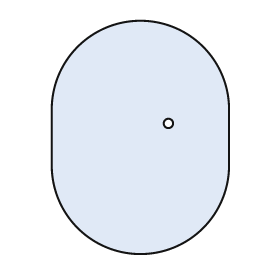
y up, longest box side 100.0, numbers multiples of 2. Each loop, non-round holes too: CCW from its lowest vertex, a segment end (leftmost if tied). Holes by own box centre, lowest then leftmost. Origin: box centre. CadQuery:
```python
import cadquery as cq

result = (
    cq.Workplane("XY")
    .moveTo(-38.0, -12.0)
    .threePointArc((0.0, -50.0), (38.0, -12.0))
    .lineTo(38.0, 12.0)
    .threePointArc((0.0, 50.0), (-38.0, 12.0))
    .close()
    .moveTo(12.0, 6.0)
    .circle(2.0)
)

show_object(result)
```